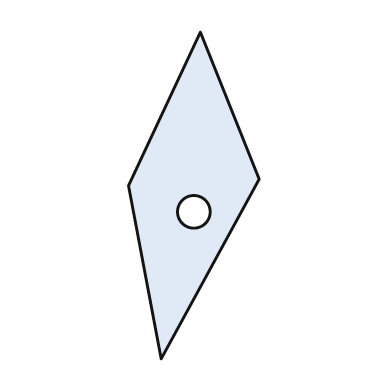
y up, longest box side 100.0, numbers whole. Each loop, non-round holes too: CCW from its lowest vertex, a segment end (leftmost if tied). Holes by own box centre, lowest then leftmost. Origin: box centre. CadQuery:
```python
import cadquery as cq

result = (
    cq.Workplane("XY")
    .moveTo(-10.0, -50.0)
    .lineTo(20.0, 5.0)
    .lineTo(2.0, 50.0)
    .lineTo(-20.0, 3.0)
    .close()
    .moveTo(0.0, -5.0)
    .circle(5.0)
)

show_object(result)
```